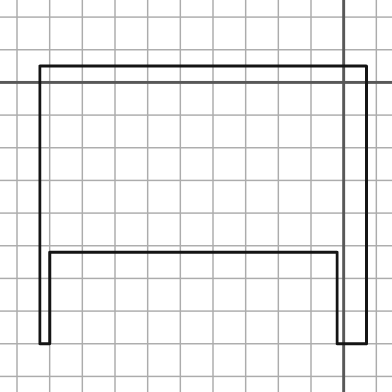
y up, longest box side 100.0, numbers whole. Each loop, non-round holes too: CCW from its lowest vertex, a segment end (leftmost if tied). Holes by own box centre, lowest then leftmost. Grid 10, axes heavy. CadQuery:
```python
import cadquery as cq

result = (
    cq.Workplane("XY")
    .moveTo(-93.0, -80.0)
    .lineTo(-90.0, -80.0)
    .lineTo(-90.0, -52.0)
    .lineTo(-2.0, -52.0)
    .lineTo(-2.0, -80.0)
    .lineTo(7.0, -80.0)
    .lineTo(7.0, 5.0)
    .lineTo(-93.0, 5.0)
    .close()
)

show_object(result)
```